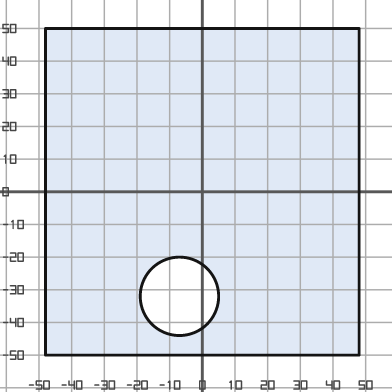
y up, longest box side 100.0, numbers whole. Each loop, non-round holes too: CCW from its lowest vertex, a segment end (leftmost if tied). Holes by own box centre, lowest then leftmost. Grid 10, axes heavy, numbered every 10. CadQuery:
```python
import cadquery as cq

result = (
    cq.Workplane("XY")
    .moveTo(-48.0, -50.0)
    .lineTo(48.0, -50.0)
    .lineTo(48.0, 50.0)
    .lineTo(-48.0, 50.0)
    .close()
    .moveTo(-7.0, -32.0)
    .circle(12.0)
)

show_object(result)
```